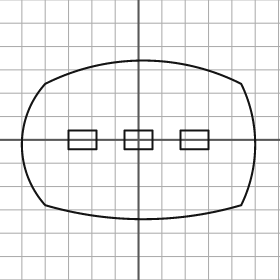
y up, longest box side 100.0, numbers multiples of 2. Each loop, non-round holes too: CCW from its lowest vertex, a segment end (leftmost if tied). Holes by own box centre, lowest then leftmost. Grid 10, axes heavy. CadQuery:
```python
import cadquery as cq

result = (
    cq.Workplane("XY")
    .moveTo(-40.0, -28.0)
    .threePointArc((2.0, -34.0), (44.0, -28.0))
    .threePointArc((50.0, -2.0), (44.0, 24.0))
    .threePointArc((2.0, 34.0), (-40.0, 24.0))
    .threePointArc((-50.0, -2.0), (-40.0, -28.0))
    .close()
    .moveTo(-30.0, -4.0)
    .lineTo(-18.0, -4.0)
    .lineTo(-18.0, 4.0)
    .lineTo(-30.0, 4.0)
    .close()
    .moveTo(-6.0, -4.0)
    .lineTo(6.0, -4.0)
    .lineTo(6.0, 4.0)
    .lineTo(-6.0, 4.0)
    .close()
    .moveTo(18.0, -4.0)
    .lineTo(30.0, -4.0)
    .lineTo(30.0, 4.0)
    .lineTo(18.0, 4.0)
    .close()
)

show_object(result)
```